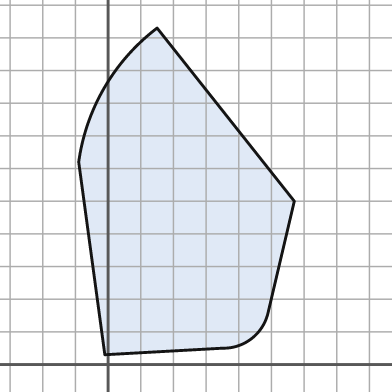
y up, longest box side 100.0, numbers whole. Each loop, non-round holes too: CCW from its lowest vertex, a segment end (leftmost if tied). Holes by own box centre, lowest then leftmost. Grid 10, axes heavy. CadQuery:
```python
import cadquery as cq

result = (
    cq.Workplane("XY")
    .moveTo(-1.0, 3.0)
    .lineTo(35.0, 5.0)
    .threePointArc((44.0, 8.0), (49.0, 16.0))
    .lineTo(57.0, 50.0)
    .lineTo(15.0, 103.0)
    .threePointArc((-1.0, 85.0), (-9.0, 62.0))
    .close()
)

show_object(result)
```